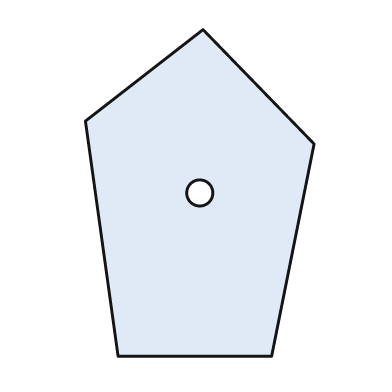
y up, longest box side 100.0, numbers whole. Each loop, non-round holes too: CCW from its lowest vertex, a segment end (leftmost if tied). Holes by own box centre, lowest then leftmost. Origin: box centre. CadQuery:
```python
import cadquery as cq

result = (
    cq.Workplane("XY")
    .moveTo(-25.0, -50.0)
    .lineTo(22.0, -50.0)
    .lineTo(35.0, 15.0)
    .lineTo(1.0, 50.0)
    .lineTo(-35.0, 22.0)
    .close()
    .moveTo(0.0, 0.0)
    .circle(4.0)
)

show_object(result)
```